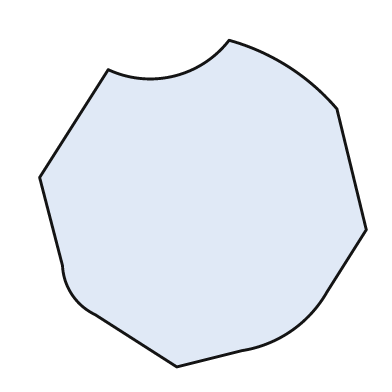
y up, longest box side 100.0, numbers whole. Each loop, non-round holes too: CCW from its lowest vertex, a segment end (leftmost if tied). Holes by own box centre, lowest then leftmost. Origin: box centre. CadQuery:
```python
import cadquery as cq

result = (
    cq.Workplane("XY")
    .moveTo(-8.0, -50.0)
    .lineTo(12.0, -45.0)
    .threePointArc((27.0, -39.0), (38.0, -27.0))
    .lineTo(50.0, -8.0)
    .lineTo(41.0, 29.0)
    .threePointArc((26.0, 42.0), (8.0, 50.0))
    .threePointArc((-9.0, 39.0), (-29.0, 41.0))
    .lineTo(-50.0, 8.0)
    .lineTo(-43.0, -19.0)
    .threePointArc((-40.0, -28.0), (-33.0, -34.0))
    .close()
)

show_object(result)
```